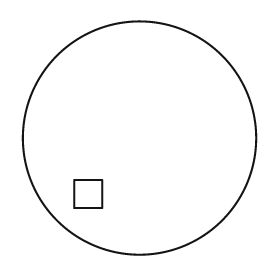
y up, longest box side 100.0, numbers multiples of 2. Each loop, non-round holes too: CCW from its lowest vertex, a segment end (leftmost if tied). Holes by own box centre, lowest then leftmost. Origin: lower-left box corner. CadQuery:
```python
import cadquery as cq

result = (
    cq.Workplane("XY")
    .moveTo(50.0, 50.0)
    .circle(50.0)
    .moveTo(22.0, 20.0)
    .lineTo(34.0, 20.0)
    .lineTo(34.0, 32.0)
    .lineTo(22.0, 32.0)
    .close()
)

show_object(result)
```